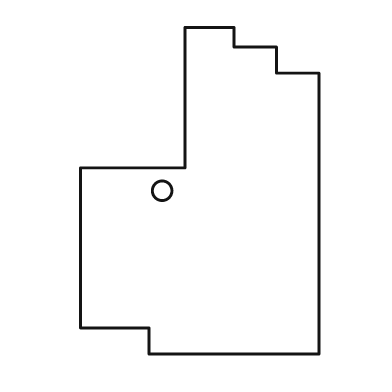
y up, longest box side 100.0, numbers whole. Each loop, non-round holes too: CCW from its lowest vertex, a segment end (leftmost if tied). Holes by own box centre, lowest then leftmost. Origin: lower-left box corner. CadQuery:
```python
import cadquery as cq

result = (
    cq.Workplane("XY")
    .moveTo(21.0, 0.0)
    .lineTo(73.0, 0.0)
    .lineTo(73.0, 86.0)
    .lineTo(60.0, 86.0)
    .lineTo(60.0, 94.0)
    .lineTo(47.0, 94.0)
    .lineTo(47.0, 100.0)
    .lineTo(32.0, 100.0)
    .lineTo(32.0, 57.0)
    .lineTo(0.0, 57.0)
    .lineTo(0.0, 8.0)
    .lineTo(21.0, 8.0)
    .close()
    .moveTo(25.0, 50.0)
    .circle(3.0)
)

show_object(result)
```